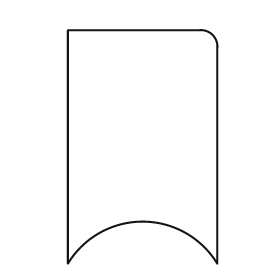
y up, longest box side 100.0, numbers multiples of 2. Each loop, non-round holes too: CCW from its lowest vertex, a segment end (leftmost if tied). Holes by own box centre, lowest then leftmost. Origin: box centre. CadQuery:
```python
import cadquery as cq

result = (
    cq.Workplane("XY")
    .moveTo(-32.0, -50.0)
    .threePointArc((0.0, -32.0), (32.0, -50.0))
    .lineTo(32.0, 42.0)
    .threePointArc((30.0, 48.0), (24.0, 50.0))
    .lineTo(-32.0, 50.0)
    .close()
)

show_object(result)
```